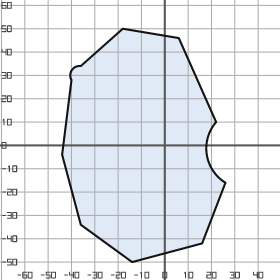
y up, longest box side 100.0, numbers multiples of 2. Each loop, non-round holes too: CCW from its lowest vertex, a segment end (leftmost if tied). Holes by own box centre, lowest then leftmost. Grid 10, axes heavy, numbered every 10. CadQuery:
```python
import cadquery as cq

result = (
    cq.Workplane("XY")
    .moveTo(-14.0, -50.0)
    .lineTo(16.0, -42.0)
    .lineTo(26.0, -16.0)
    .threePointArc((18.0, -4.0), (22.0, 10.0))
    .lineTo(6.0, 46.0)
    .lineTo(-18.0, 50.0)
    .lineTo(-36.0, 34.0)
    .threePointArc((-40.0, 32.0), (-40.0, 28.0))
    .lineTo(-44.0, -4.0)
    .lineTo(-36.0, -34.0)
    .close()
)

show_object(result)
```